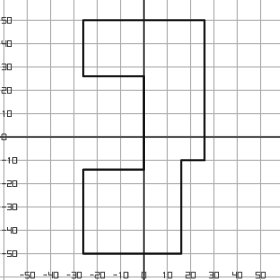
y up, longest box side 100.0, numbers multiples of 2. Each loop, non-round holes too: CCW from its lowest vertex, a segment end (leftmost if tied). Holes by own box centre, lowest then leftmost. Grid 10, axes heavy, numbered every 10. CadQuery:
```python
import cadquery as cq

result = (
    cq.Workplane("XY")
    .moveTo(-26.0, -50.0)
    .lineTo(16.0, -50.0)
    .lineTo(16.0, -10.0)
    .lineTo(26.0, -10.0)
    .lineTo(26.0, 50.0)
    .lineTo(-26.0, 50.0)
    .lineTo(-26.0, 26.0)
    .lineTo(0.0, 26.0)
    .lineTo(0.0, -14.0)
    .lineTo(-26.0, -14.0)
    .close()
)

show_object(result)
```